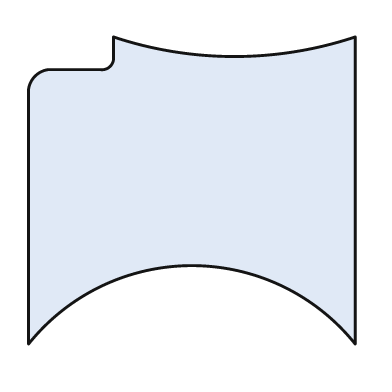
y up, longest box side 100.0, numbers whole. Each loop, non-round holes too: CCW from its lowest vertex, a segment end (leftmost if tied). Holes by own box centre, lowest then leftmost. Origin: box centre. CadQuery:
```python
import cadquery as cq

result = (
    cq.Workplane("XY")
    .moveTo(-50.0, -47.0)
    .threePointArc((0.0, -23.0), (50.0, -47.0))
    .lineTo(50.0, 47.0)
    .threePointArc((13.0, 41.0), (-24.0, 47.0))
    .lineTo(-24.0, 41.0)
    .threePointArc((-25.0, 38.0), (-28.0, 37.0))
    .lineTo(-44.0, 37.0)
    .threePointArc((-48.0, 35.0), (-50.0, 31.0))
    .close()
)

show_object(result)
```